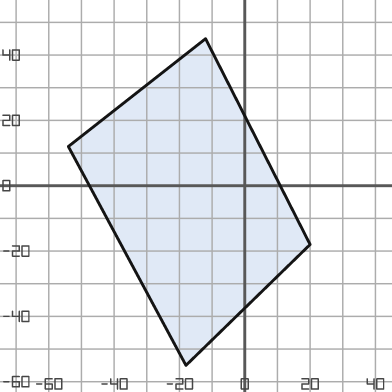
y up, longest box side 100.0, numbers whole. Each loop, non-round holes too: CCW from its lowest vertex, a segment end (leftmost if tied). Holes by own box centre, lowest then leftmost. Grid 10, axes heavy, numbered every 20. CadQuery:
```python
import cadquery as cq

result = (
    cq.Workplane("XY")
    .moveTo(-18.0, -55.0)
    .lineTo(20.0, -18.0)
    .lineTo(-12.0, 45.0)
    .lineTo(-54.0, 12.0)
    .close()
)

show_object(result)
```